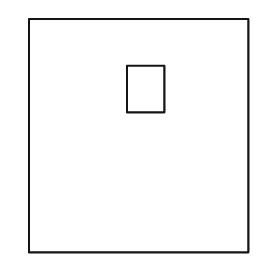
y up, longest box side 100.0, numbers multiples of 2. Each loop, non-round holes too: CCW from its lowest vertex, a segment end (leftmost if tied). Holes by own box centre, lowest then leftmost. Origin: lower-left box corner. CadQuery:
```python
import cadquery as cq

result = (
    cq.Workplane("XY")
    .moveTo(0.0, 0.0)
    .lineTo(94.0, 0.0)
    .lineTo(94.0, 100.0)
    .lineTo(0.0, 100.0)
    .close()
    .moveTo(42.0, 60.0)
    .lineTo(58.0, 60.0)
    .lineTo(58.0, 80.0)
    .lineTo(42.0, 80.0)
    .close()
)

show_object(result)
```